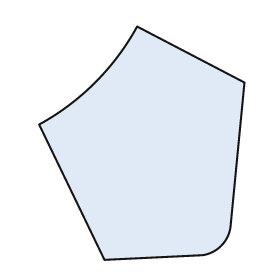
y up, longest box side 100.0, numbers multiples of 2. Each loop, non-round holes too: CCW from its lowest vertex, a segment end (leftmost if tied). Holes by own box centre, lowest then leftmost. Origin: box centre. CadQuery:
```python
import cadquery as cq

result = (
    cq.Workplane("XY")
    .moveTo(-16.0, -50.0)
    .lineTo(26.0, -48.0)
    .threePointArc((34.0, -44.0), (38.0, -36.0))
    .lineTo(44.0, 26.0)
    .lineTo(-2.0, 50.0)
    .threePointArc((-20.0, 26.0), (-44.0, 8.0))
    .close()
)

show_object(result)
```